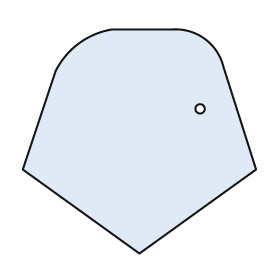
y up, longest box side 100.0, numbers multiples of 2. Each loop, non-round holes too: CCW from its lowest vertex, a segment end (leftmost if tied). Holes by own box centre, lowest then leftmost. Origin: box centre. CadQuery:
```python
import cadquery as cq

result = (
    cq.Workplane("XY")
    .moveTo(0.0, -48.0)
    .lineTo(50.0, -12.0)
    .lineTo(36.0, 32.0)
    .threePointArc((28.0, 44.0), (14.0, 48.0))
    .lineTo(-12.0, 48.0)
    .threePointArc((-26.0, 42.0), (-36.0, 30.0))
    .lineTo(-50.0, -12.0)
    .close()
    .moveTo(26.0, 14.0)
    .circle(2.0)
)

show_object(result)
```